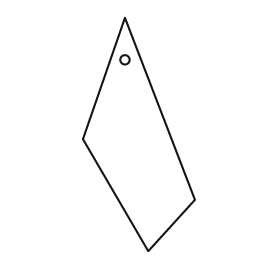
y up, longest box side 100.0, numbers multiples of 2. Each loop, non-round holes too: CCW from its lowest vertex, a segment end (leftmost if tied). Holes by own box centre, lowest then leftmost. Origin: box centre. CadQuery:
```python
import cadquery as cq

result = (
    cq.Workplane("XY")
    .moveTo(4.0, -50.0)
    .lineTo(24.0, -28.0)
    .lineTo(-6.0, 50.0)
    .lineTo(-24.0, -2.0)
    .close()
    .moveTo(-6.0, 32.0)
    .circle(2.0)
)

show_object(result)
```